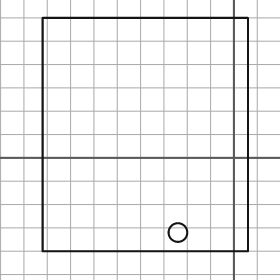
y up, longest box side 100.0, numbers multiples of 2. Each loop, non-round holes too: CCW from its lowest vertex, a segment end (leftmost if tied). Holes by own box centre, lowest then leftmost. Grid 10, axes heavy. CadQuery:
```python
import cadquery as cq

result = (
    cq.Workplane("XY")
    .moveTo(-82.0, -40.0)
    .lineTo(6.0, -40.0)
    .lineTo(6.0, 60.0)
    .lineTo(-82.0, 60.0)
    .close()
    .moveTo(-24.0, -32.0)
    .circle(4.0)
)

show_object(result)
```